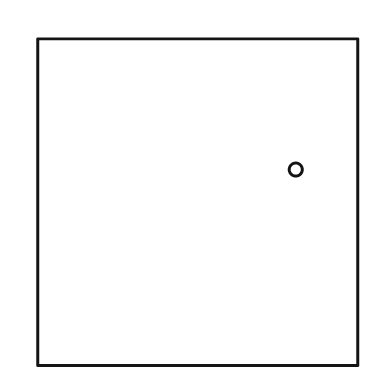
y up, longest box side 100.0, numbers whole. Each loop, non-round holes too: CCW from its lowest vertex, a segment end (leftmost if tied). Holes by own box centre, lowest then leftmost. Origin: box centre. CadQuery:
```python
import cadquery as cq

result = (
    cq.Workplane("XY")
    .moveTo(-49.0, -50.0)
    .lineTo(49.0, -50.0)
    .lineTo(49.0, 50.0)
    .lineTo(-49.0, 50.0)
    .close()
    .moveTo(30.0, 10.0)
    .circle(2.0)
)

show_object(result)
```